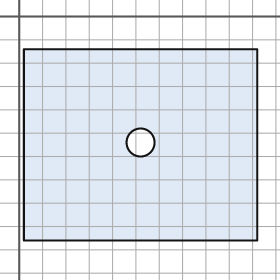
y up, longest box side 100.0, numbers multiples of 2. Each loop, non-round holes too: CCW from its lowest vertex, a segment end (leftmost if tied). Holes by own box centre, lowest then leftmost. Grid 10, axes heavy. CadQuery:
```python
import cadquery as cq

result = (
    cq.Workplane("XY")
    .moveTo(2.0, -96.0)
    .lineTo(102.0, -96.0)
    .lineTo(102.0, -14.0)
    .lineTo(2.0, -14.0)
    .close()
    .moveTo(52.0, -54.0)
    .circle(6.0)
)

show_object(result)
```